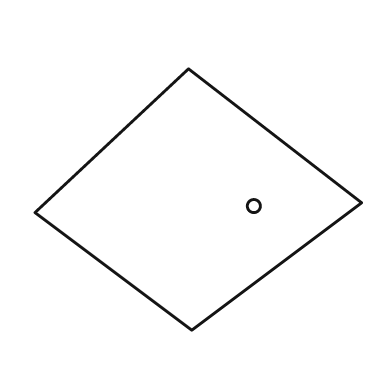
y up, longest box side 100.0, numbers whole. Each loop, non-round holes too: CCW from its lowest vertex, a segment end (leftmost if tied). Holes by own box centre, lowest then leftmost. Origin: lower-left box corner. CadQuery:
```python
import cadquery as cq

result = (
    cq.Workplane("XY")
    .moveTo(48.0, 0.0)
    .lineTo(100.0, 39.0)
    .lineTo(47.0, 80.0)
    .lineTo(0.0, 36.0)
    .close()
    .moveTo(67.0, 38.0)
    .circle(2.0)
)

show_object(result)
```